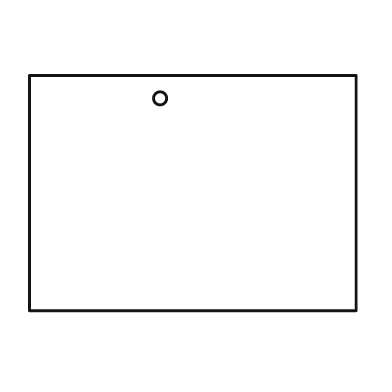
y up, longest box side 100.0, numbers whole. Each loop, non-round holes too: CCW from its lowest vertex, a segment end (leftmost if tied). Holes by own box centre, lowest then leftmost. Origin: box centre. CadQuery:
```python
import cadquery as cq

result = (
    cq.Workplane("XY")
    .moveTo(-50.0, -36.0)
    .lineTo(50.0, -36.0)
    .lineTo(50.0, 36.0)
    .lineTo(-50.0, 36.0)
    .close()
    .moveTo(-10.0, 29.0)
    .circle(2.0)
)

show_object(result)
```